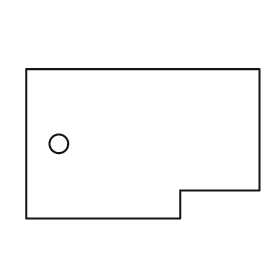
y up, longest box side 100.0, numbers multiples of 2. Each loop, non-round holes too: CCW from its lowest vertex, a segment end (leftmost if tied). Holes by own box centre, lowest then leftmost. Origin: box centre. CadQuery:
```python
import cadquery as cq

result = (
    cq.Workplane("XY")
    .moveTo(-50.0, -32.0)
    .lineTo(16.0, -32.0)
    .lineTo(16.0, -20.0)
    .lineTo(50.0, -20.0)
    .lineTo(50.0, 32.0)
    .lineTo(-50.0, 32.0)
    .close()
    .moveTo(-36.0, 0.0)
    .circle(4.0)
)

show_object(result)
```